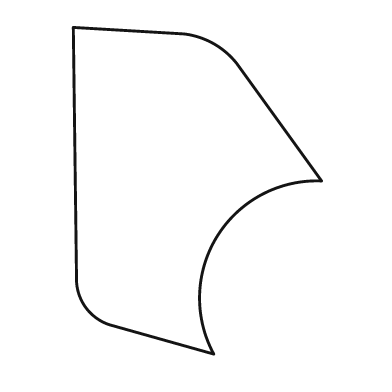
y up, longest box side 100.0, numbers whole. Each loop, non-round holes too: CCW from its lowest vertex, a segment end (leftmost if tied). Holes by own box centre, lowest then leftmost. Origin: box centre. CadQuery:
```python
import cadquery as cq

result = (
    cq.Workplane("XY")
    .moveTo(5.0, -50.0)
    .threePointArc((6.0, -14.0), (38.0, 3.0))
    .lineTo(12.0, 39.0)
    .threePointArc((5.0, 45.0), (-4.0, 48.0))
    .lineTo(-38.0, 50.0)
    .lineTo(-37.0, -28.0)
    .threePointArc((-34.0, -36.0), (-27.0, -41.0))
    .close()
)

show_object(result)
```